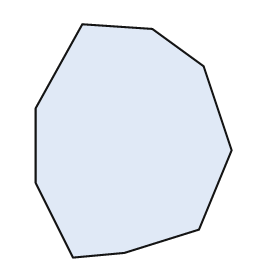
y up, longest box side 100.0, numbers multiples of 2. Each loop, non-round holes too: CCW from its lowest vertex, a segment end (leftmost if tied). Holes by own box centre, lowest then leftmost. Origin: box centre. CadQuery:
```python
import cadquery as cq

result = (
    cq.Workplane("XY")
    .moveTo(-26.0, -50.0)
    .lineTo(-4.0, -48.0)
    .lineTo(28.0, -38.0)
    .lineTo(42.0, -4.0)
    .lineTo(30.0, 32.0)
    .lineTo(8.0, 48.0)
    .lineTo(-22.0, 50.0)
    .lineTo(-42.0, 14.0)
    .lineTo(-42.0, -18.0)
    .close()
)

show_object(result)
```